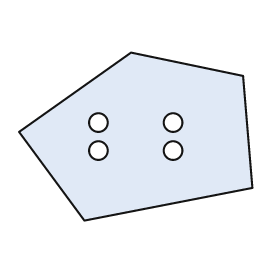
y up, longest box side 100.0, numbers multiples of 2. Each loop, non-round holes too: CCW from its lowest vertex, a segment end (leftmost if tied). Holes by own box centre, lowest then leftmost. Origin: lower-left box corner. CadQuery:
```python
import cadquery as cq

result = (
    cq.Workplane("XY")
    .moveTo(28.0, 0.0)
    .lineTo(100.0, 14.0)
    .lineTo(96.0, 62.0)
    .lineTo(48.0, 72.0)
    .lineTo(0.0, 38.0)
    .close()
    .moveTo(34.0, 30.0)
    .circle(4.0)
    .moveTo(66.0, 30.0)
    .circle(4.0)
    .moveTo(34.0, 42.0)
    .circle(4.0)
    .moveTo(66.0, 42.0)
    .circle(4.0)
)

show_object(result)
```